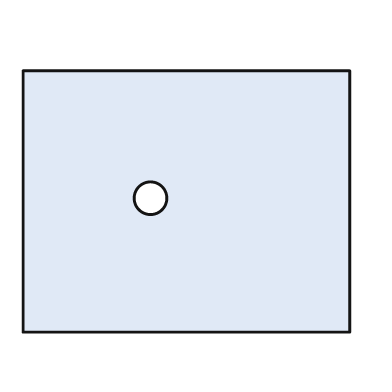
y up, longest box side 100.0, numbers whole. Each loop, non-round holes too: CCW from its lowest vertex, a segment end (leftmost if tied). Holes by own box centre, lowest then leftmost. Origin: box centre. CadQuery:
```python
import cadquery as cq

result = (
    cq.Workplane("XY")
    .moveTo(-50.0, -40.0)
    .lineTo(50.0, -40.0)
    .lineTo(50.0, 40.0)
    .lineTo(-50.0, 40.0)
    .close()
    .moveTo(-11.0, 1.0)
    .circle(5.0)
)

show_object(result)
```